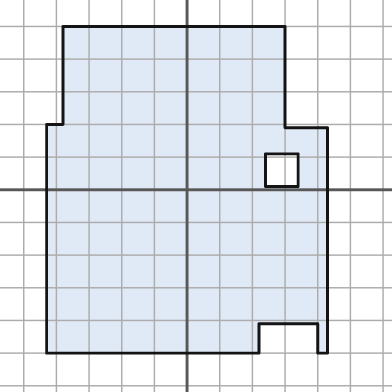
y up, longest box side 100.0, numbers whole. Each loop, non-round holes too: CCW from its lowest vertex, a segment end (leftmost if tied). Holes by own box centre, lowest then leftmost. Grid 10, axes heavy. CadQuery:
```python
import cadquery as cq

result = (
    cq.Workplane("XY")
    .moveTo(-43.0, -50.0)
    .lineTo(22.0, -50.0)
    .lineTo(22.0, -41.0)
    .lineTo(40.0, -41.0)
    .lineTo(40.0, -50.0)
    .lineTo(43.0, -50.0)
    .lineTo(43.0, 19.0)
    .lineTo(30.0, 19.0)
    .lineTo(30.0, 50.0)
    .lineTo(-38.0, 50.0)
    .lineTo(-38.0, 20.0)
    .lineTo(-43.0, 20.0)
    .close()
    .moveTo(24.0, 1.0)
    .lineTo(34.0, 1.0)
    .lineTo(34.0, 11.0)
    .lineTo(24.0, 11.0)
    .close()
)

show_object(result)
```